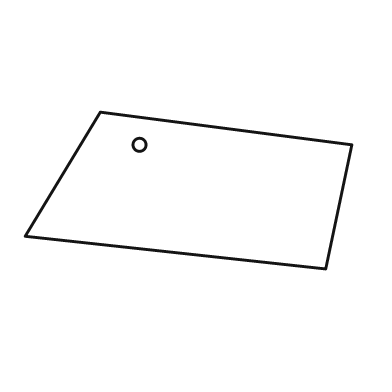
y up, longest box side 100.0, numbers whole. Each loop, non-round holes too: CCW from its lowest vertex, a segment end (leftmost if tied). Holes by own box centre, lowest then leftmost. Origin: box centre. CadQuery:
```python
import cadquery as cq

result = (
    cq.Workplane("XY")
    .moveTo(42.0, -24.0)
    .lineTo(50.0, 14.0)
    .lineTo(-27.0, 24.0)
    .lineTo(-50.0, -14.0)
    .close()
    .moveTo(-15.0, 14.0)
    .circle(2.0)
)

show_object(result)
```